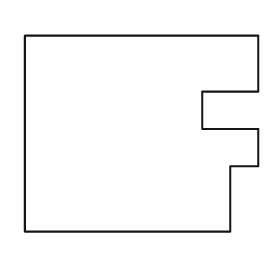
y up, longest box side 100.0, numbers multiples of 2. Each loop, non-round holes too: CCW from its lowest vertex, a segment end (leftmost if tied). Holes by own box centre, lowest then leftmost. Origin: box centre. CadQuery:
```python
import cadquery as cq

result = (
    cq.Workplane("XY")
    .moveTo(-50.0, -42.0)
    .lineTo(38.0, -42.0)
    .lineTo(38.0, -14.0)
    .lineTo(50.0, -14.0)
    .lineTo(50.0, 2.0)
    .lineTo(26.0, 2.0)
    .lineTo(26.0, 18.0)
    .lineTo(50.0, 18.0)
    .lineTo(50.0, 42.0)
    .lineTo(-50.0, 42.0)
    .close()
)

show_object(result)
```